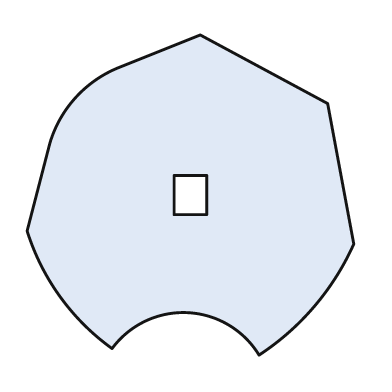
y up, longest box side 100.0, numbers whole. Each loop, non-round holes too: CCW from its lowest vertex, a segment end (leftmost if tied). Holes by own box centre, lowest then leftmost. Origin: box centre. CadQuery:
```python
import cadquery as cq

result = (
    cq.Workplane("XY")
    .moveTo(21.0, -49.0)
    .threePointArc((38.0, -34.0), (50.0, -15.0))
    .lineTo(42.0, 28.0)
    .lineTo(3.0, 49.0)
    .lineTo(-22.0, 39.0)
    .threePointArc((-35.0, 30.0), (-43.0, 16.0))
    .lineTo(-50.0, -11.0)
    .threePointArc((-40.0, -31.0), (-24.0, -47.0))
    .threePointArc((-1.0, -36.0), (21.0, -49.0))
    .close()
    .moveTo(-5.0, -6.0)
    .lineTo(5.0, -6.0)
    .lineTo(5.0, 6.0)
    .lineTo(-5.0, 6.0)
    .close()
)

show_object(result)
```